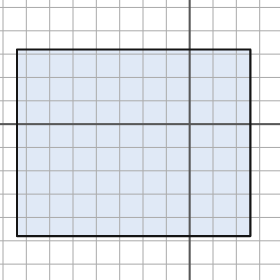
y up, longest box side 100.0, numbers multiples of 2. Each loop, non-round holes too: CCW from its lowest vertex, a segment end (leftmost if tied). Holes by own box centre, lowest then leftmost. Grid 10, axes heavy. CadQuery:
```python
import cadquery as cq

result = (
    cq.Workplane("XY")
    .moveTo(-74.0, -48.0)
    .lineTo(26.0, -48.0)
    .lineTo(26.0, 32.0)
    .lineTo(-74.0, 32.0)
    .close()
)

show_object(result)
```